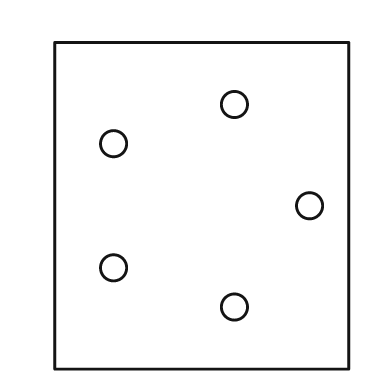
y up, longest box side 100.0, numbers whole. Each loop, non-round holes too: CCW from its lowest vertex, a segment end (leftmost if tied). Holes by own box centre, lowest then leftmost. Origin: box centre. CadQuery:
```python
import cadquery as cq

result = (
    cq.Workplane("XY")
    .moveTo(-45.0, -50.0)
    .lineTo(45.0, -50.0)
    .lineTo(45.0, 50.0)
    .lineTo(-45.0, 50.0)
    .close()
    .moveTo(10.0, -31.0)
    .circle(4.0)
    .moveTo(-27.0, -19.0)
    .circle(4.0)
    .moveTo(33.0, 0.0)
    .circle(4.0)
    .moveTo(-27.0, 19.0)
    .circle(4.0)
    .moveTo(10.0, 31.0)
    .circle(4.0)
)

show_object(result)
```